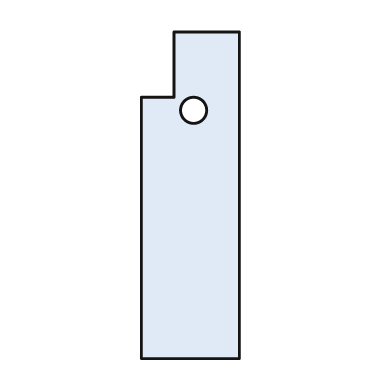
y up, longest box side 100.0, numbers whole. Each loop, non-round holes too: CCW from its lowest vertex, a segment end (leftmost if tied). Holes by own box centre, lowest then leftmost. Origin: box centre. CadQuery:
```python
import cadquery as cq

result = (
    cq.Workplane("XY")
    .moveTo(-15.0, -50.0)
    .lineTo(15.0, -50.0)
    .lineTo(15.0, 50.0)
    .lineTo(-5.0, 50.0)
    .lineTo(-5.0, 30.0)
    .lineTo(-15.0, 30.0)
    .close()
    .moveTo(1.0, 26.0)
    .circle(4.0)
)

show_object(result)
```